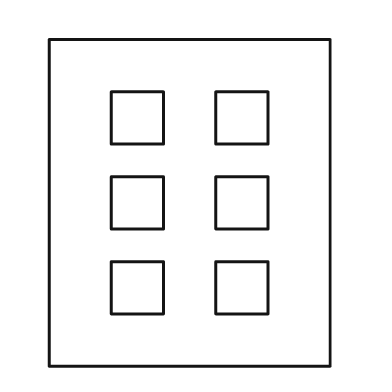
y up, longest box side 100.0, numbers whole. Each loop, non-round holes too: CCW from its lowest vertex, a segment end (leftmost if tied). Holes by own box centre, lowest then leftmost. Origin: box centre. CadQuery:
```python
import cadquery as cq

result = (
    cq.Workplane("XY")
    .moveTo(-43.0, -50.0)
    .lineTo(43.0, -50.0)
    .lineTo(43.0, 50.0)
    .lineTo(-43.0, 50.0)
    .close()
    .moveTo(-24.0, -34.0)
    .lineTo(-8.0, -34.0)
    .lineTo(-8.0, -18.0)
    .lineTo(-24.0, -18.0)
    .close()
    .moveTo(8.0, -34.0)
    .lineTo(24.0, -34.0)
    .lineTo(24.0, -18.0)
    .lineTo(8.0, -18.0)
    .close()
    .moveTo(-24.0, -8.0)
    .lineTo(-8.0, -8.0)
    .lineTo(-8.0, 8.0)
    .lineTo(-24.0, 8.0)
    .close()
    .moveTo(8.0, -8.0)
    .lineTo(24.0, -8.0)
    .lineTo(24.0, 8.0)
    .lineTo(8.0, 8.0)
    .close()
    .moveTo(-24.0, 18.0)
    .lineTo(-8.0, 18.0)
    .lineTo(-8.0, 34.0)
    .lineTo(-24.0, 34.0)
    .close()
    .moveTo(8.0, 18.0)
    .lineTo(24.0, 18.0)
    .lineTo(24.0, 34.0)
    .lineTo(8.0, 34.0)
    .close()
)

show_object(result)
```